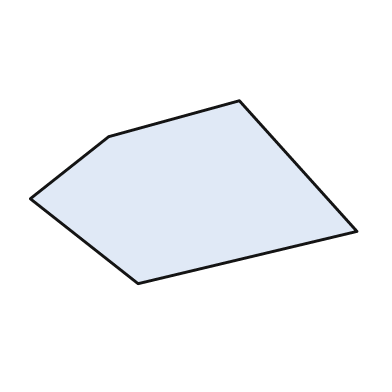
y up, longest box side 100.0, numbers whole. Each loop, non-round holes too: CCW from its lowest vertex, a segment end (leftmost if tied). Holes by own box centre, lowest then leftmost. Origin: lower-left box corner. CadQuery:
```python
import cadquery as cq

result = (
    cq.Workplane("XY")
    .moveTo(33.0, 0.0)
    .lineTo(100.0, 16.0)
    .lineTo(64.0, 56.0)
    .lineTo(24.0, 45.0)
    .lineTo(0.0, 26.0)
    .close()
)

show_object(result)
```